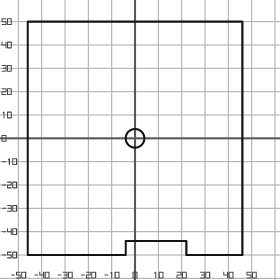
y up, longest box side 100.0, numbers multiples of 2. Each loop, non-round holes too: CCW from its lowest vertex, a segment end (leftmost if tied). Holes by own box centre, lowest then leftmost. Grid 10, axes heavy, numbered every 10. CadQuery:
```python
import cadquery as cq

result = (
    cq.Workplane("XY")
    .moveTo(-46.0, -50.0)
    .lineTo(-4.0, -50.0)
    .lineTo(-4.0, -44.0)
    .lineTo(22.0, -44.0)
    .lineTo(22.0, -50.0)
    .lineTo(46.0, -50.0)
    .lineTo(46.0, 50.0)
    .lineTo(-46.0, 50.0)
    .close()
    .moveTo(0.0, 0.0)
    .circle(4.0)
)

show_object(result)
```